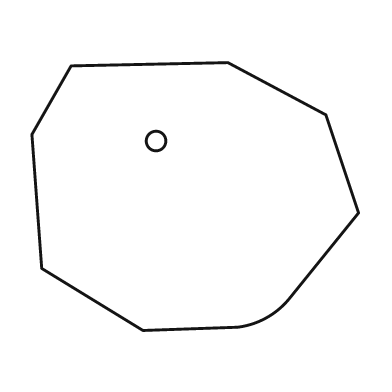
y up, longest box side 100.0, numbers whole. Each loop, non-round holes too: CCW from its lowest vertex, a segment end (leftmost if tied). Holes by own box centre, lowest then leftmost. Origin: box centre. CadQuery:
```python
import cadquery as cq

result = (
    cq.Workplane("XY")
    .moveTo(-16.0, -41.0)
    .lineTo(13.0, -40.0)
    .threePointArc((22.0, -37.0), (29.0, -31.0))
    .lineTo(50.0, -5.0)
    .lineTo(40.0, 25.0)
    .lineTo(10.0, 41.0)
    .lineTo(-38.0, 40.0)
    .lineTo(-50.0, 19.0)
    .lineTo(-47.0, -22.0)
    .close()
    .moveTo(-12.0, 17.0)
    .circle(3.0)
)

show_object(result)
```